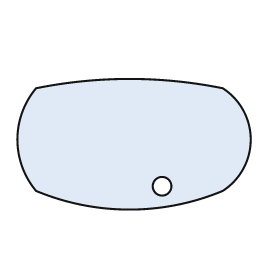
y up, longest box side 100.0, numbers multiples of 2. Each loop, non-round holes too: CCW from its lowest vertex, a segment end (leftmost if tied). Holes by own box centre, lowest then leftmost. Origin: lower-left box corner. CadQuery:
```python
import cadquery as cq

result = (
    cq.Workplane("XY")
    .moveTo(8.0, 8.0)
    .threePointArc((48.0, 0.0), (88.0, 8.0))
    .threePointArc((100.0, 30.0), (88.0, 52.0))
    .threePointArc((48.0, 56.0), (8.0, 52.0))
    .threePointArc((0.0, 30.0), (8.0, 8.0))
    .close()
    .moveTo(62.0, 10.0)
    .circle(4.0)
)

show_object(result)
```